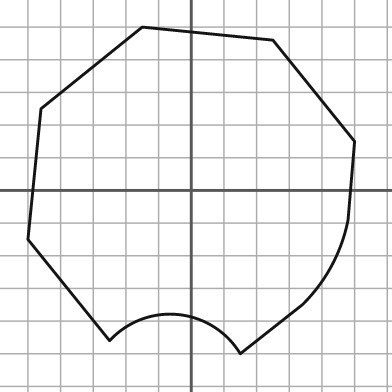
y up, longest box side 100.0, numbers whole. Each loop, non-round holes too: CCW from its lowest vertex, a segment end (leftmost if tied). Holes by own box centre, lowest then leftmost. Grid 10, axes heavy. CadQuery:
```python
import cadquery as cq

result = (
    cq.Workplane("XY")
    .moveTo(15.0, -50.0)
    .lineTo(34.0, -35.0)
    .threePointArc((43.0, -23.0), (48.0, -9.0))
    .lineTo(50.0, 15.0)
    .lineTo(25.0, 46.0)
    .lineTo(-15.0, 50.0)
    .lineTo(-46.0, 25.0)
    .lineTo(-50.0, -15.0)
    .lineTo(-25.0, -46.0)
    .threePointArc((-4.0, -38.0), (15.0, -50.0))
    .close()
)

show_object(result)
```